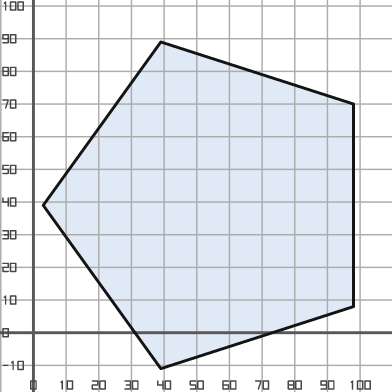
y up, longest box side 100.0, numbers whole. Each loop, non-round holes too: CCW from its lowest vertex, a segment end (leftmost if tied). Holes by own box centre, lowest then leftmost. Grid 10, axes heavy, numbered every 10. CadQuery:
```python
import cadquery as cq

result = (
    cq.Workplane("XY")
    .moveTo(39.0, -11.0)
    .lineTo(98.0, 8.0)
    .lineTo(98.0, 70.0)
    .lineTo(39.0, 89.0)
    .lineTo(3.0, 39.0)
    .close()
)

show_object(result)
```